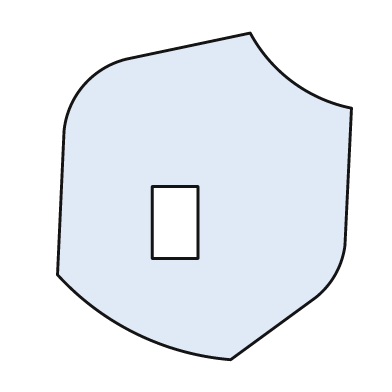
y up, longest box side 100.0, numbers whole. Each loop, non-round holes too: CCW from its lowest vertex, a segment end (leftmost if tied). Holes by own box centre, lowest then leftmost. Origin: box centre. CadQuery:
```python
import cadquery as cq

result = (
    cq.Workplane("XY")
    .moveTo(8.0, -50.0)
    .lineTo(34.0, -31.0)
    .threePointArc((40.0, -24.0), (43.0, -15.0))
    .lineTo(45.0, 27.0)
    .threePointArc((27.0, 35.0), (14.0, 50.0))
    .lineTo(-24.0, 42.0)
    .threePointArc((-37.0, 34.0), (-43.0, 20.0))
    .lineTo(-45.0, -24.0)
    .threePointArc((-21.0, -42.0), (8.0, -50.0))
    .close()
    .moveTo(-16.0, -19.0)
    .lineTo(-2.0, -19.0)
    .lineTo(-2.0, 3.0)
    .lineTo(-16.0, 3.0)
    .close()
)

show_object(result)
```